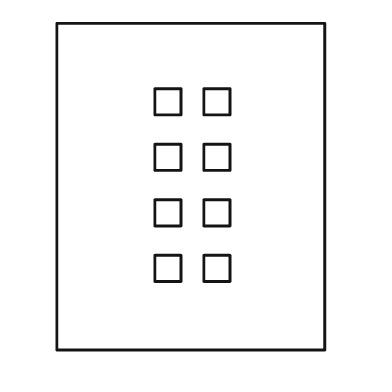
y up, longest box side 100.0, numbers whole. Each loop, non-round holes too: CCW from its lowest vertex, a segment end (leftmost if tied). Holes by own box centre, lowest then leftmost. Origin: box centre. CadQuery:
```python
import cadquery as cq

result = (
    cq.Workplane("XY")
    .moveTo(-41.0, -50.0)
    .lineTo(41.0, -50.0)
    .lineTo(41.0, 50.0)
    .lineTo(-41.0, 50.0)
    .close()
    .moveTo(-11.0, -29.0)
    .lineTo(-3.0, -29.0)
    .lineTo(-3.0, -21.0)
    .lineTo(-11.0, -21.0)
    .close()
    .moveTo(4.0, -29.0)
    .lineTo(12.0, -29.0)
    .lineTo(12.0, -21.0)
    .lineTo(4.0, -21.0)
    .close()
    .moveTo(-11.0, -12.0)
    .lineTo(-3.0, -12.0)
    .lineTo(-3.0, -4.0)
    .lineTo(-11.0, -4.0)
    .close()
    .moveTo(4.0, -12.0)
    .lineTo(12.0, -12.0)
    .lineTo(12.0, -4.0)
    .lineTo(4.0, -4.0)
    .close()
    .moveTo(-11.0, 5.0)
    .lineTo(-3.0, 5.0)
    .lineTo(-3.0, 13.0)
    .lineTo(-11.0, 13.0)
    .close()
    .moveTo(4.0, 5.0)
    .lineTo(12.0, 5.0)
    .lineTo(12.0, 13.0)
    .lineTo(4.0, 13.0)
    .close()
    .moveTo(-11.0, 22.0)
    .lineTo(-3.0, 22.0)
    .lineTo(-3.0, 30.0)
    .lineTo(-11.0, 30.0)
    .close()
    .moveTo(4.0, 22.0)
    .lineTo(12.0, 22.0)
    .lineTo(12.0, 30.0)
    .lineTo(4.0, 30.0)
    .close()
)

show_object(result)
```